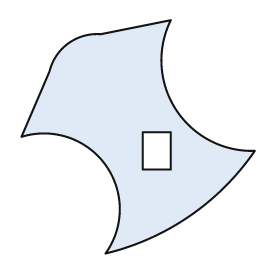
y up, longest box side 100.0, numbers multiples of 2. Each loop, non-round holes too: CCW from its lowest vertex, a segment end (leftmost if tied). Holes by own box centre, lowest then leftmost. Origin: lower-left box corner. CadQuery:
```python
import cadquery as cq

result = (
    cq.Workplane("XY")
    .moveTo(36.0, 0.0)
    .threePointArc((72.0, 16.0), (100.0, 44.0))
    .threePointArc((66.0, 62.0), (64.0, 100.0))
    .lineTo(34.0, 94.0)
    .threePointArc((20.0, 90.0), (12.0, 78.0))
    .lineTo(0.0, 50.0)
    .threePointArc((36.0, 38.0), (36.0, 0.0))
    .close()
    .moveTo(52.0, 36.0)
    .lineTo(64.0, 36.0)
    .lineTo(64.0, 52.0)
    .lineTo(52.0, 52.0)
    .close()
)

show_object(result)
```